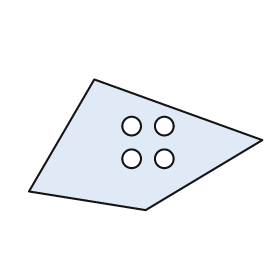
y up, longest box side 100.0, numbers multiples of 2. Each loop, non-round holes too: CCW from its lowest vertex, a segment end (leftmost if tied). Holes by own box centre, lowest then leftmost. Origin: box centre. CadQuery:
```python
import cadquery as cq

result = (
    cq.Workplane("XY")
    .moveTo(0.0, -28.0)
    .lineTo(50.0, 2.0)
    .lineTo(-22.0, 28.0)
    .lineTo(-50.0, -20.0)
    .close()
    .moveTo(-6.0, -6.0)
    .circle(4.0)
    .moveTo(8.0, -6.0)
    .circle(4.0)
    .moveTo(-6.0, 8.0)
    .circle(4.0)
    .moveTo(8.0, 8.0)
    .circle(4.0)
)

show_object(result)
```